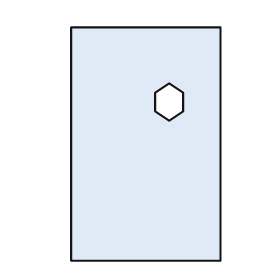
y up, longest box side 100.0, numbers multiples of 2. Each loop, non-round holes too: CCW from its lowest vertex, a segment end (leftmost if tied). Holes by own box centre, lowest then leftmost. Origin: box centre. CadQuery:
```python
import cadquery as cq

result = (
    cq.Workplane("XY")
    .moveTo(-32.0, -50.0)
    .lineTo(32.0, -50.0)
    .lineTo(32.0, 50.0)
    .lineTo(-32.0, 50.0)
    .close()
    .moveTo(10.0, 10.0)
    .lineTo(16.0, 14.0)
    .lineTo(16.0, 22.0)
    .lineTo(10.0, 26.0)
    .lineTo(4.0, 22.0)
    .lineTo(4.0, 14.0)
    .close()
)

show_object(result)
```